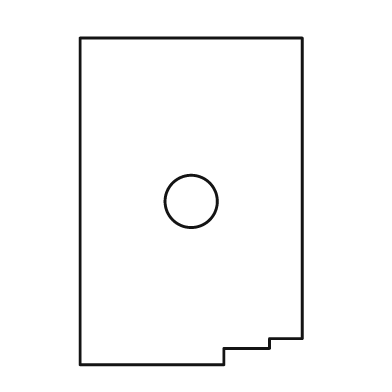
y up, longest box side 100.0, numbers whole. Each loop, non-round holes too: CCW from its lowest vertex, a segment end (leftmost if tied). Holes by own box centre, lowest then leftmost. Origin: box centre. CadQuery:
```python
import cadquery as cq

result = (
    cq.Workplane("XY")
    .moveTo(-34.0, -50.0)
    .lineTo(10.0, -50.0)
    .lineTo(10.0, -45.0)
    .lineTo(24.0, -45.0)
    .lineTo(24.0, -42.0)
    .lineTo(34.0, -42.0)
    .lineTo(34.0, 50.0)
    .lineTo(-34.0, 50.0)
    .close()
    .moveTo(0.0, 0.0)
    .circle(8.0)
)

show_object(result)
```